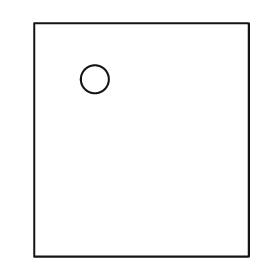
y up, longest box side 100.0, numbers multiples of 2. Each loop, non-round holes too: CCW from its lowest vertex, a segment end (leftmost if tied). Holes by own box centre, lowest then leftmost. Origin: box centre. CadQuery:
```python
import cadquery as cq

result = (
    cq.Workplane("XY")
    .moveTo(-46.0, -50.0)
    .lineTo(46.0, -50.0)
    .lineTo(46.0, 50.0)
    .lineTo(-46.0, 50.0)
    .close()
    .moveTo(-20.0, 26.0)
    .circle(6.0)
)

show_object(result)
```